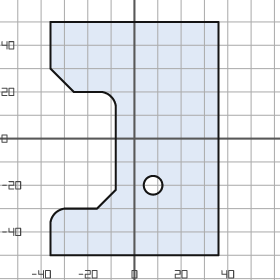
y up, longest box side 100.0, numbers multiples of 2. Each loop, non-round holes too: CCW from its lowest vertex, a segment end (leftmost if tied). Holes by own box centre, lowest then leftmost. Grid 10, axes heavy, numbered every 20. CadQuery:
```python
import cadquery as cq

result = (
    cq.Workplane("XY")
    .moveTo(-36.0, -50.0)
    .lineTo(36.0, -50.0)
    .lineTo(36.0, 50.0)
    .lineTo(-36.0, 50.0)
    .lineTo(-36.0, 30.0)
    .lineTo(-26.0, 20.0)
    .lineTo(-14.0, 20.0)
    .threePointArc((-10.0, 18.0), (-8.0, 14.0))
    .lineTo(-8.0, -22.0)
    .lineTo(-16.0, -30.0)
    .lineTo(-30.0, -30.0)
    .threePointArc((-34.0, -32.0), (-36.0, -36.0))
    .close()
    .moveTo(8.0, -20.0)
    .circle(4.0)
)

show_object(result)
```